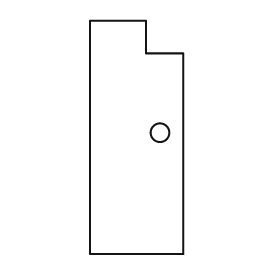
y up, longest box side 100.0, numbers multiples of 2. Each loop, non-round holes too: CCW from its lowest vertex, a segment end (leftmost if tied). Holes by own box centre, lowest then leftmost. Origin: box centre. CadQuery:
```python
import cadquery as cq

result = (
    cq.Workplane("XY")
    .moveTo(-20.0, -50.0)
    .lineTo(20.0, -50.0)
    .lineTo(20.0, 36.0)
    .lineTo(4.0, 36.0)
    .lineTo(4.0, 50.0)
    .lineTo(-20.0, 50.0)
    .close()
    .moveTo(10.0, 2.0)
    .circle(4.0)
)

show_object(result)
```